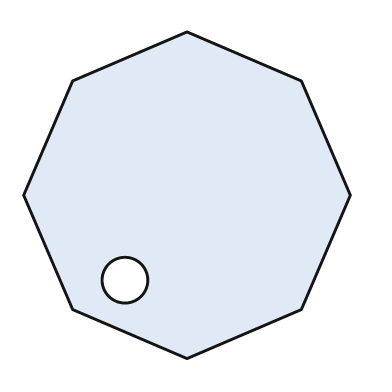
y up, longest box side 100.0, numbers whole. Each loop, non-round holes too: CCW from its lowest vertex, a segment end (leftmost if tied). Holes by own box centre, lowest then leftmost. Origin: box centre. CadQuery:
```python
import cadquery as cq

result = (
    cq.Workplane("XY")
    .moveTo(0.0, -50.0)
    .lineTo(35.0, -35.0)
    .lineTo(50.0, 0.0)
    .lineTo(35.0, 35.0)
    .lineTo(0.0, 50.0)
    .lineTo(-35.0, 35.0)
    .lineTo(-50.0, 0.0)
    .lineTo(-35.0, -35.0)
    .close()
    .moveTo(-19.0, -26.0)
    .circle(7.0)
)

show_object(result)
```